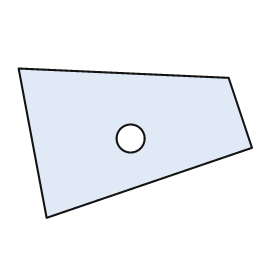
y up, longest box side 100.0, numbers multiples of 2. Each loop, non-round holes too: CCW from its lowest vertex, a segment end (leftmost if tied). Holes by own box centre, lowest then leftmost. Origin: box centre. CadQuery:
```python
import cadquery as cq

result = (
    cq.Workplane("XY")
    .moveTo(-38.0, -32.0)
    .lineTo(50.0, -2.0)
    .lineTo(40.0, 28.0)
    .lineTo(-50.0, 32.0)
    .close()
    .moveTo(-2.0, 2.0)
    .circle(6.0)
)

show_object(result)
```